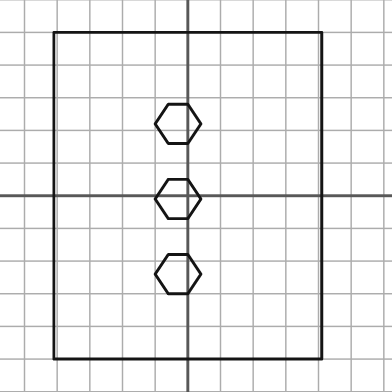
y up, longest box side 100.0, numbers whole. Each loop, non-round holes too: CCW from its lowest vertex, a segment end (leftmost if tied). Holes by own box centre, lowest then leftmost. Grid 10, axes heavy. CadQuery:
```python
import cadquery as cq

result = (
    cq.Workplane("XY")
    .moveTo(-41.0, -50.0)
    .lineTo(41.0, -50.0)
    .lineTo(41.0, 50.0)
    .lineTo(-41.0, 50.0)
    .close()
    .moveTo(-6.0, -30.0)
    .lineTo(0.0, -30.0)
    .lineTo(4.0, -24.0)
    .lineTo(0.0, -18.0)
    .lineTo(-6.0, -18.0)
    .lineTo(-10.0, -24.0)
    .close()
    .moveTo(-6.0, -7.0)
    .lineTo(0.0, -7.0)
    .lineTo(4.0, -1.0)
    .lineTo(0.0, 5.0)
    .lineTo(-6.0, 5.0)
    .lineTo(-10.0, -1.0)
    .close()
    .moveTo(-6.0, 16.0)
    .lineTo(0.0, 16.0)
    .lineTo(4.0, 22.0)
    .lineTo(0.0, 28.0)
    .lineTo(-6.0, 28.0)
    .lineTo(-10.0, 22.0)
    .close()
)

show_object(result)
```